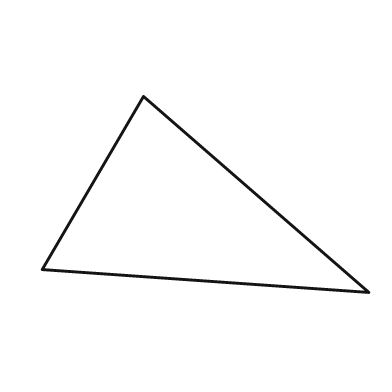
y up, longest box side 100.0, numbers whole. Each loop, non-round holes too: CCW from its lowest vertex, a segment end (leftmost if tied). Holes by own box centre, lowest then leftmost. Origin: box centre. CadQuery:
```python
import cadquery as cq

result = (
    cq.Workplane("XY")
    .moveTo(50.0, -30.0)
    .lineTo(-19.0, 30.0)
    .lineTo(-50.0, -23.0)
    .close()
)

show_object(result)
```